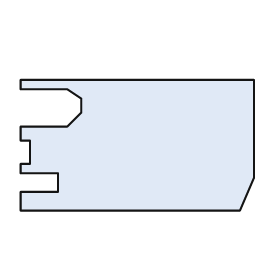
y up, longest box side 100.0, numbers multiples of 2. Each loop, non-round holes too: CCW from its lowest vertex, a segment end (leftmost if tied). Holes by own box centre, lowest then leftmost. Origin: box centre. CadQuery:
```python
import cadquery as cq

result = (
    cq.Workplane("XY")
    .moveTo(-50.0, -28.0)
    .lineTo(44.0, -28.0)
    .lineTo(50.0, -14.0)
    .lineTo(50.0, 28.0)
    .lineTo(-50.0, 28.0)
    .lineTo(-50.0, 24.0)
    .lineTo(-30.0, 24.0)
    .lineTo(-24.0, 20.0)
    .lineTo(-24.0, 14.0)
    .lineTo(-30.0, 8.0)
    .lineTo(-50.0, 8.0)
    .lineTo(-50.0, 2.0)
    .lineTo(-46.0, 2.0)
    .lineTo(-46.0, -8.0)
    .lineTo(-50.0, -8.0)
    .lineTo(-50.0, -12.0)
    .lineTo(-34.0, -12.0)
    .lineTo(-34.0, -20.0)
    .lineTo(-50.0, -20.0)
    .close()
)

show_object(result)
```